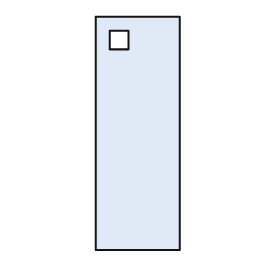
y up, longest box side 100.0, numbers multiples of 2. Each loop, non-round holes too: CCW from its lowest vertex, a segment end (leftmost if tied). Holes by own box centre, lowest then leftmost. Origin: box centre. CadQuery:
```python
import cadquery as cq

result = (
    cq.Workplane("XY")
    .moveTo(-18.0, -50.0)
    .lineTo(18.0, -50.0)
    .lineTo(18.0, 50.0)
    .lineTo(-18.0, 50.0)
    .close()
    .moveTo(-12.0, 36.0)
    .lineTo(-4.0, 36.0)
    .lineTo(-4.0, 44.0)
    .lineTo(-12.0, 44.0)
    .close()
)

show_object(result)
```